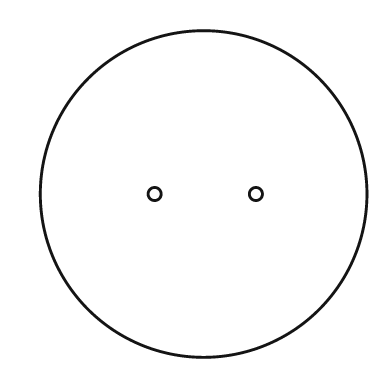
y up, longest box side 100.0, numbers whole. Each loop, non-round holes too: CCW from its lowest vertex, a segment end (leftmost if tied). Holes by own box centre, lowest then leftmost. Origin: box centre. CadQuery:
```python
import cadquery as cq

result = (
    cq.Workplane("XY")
    .moveTo(0.0, 0.0)
    .circle(50.0)
    .moveTo(-15.0, 0.0)
    .circle(2.0)
    .moveTo(16.0, 0.0)
    .circle(2.0)
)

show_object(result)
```